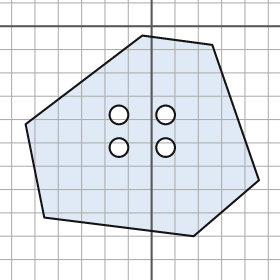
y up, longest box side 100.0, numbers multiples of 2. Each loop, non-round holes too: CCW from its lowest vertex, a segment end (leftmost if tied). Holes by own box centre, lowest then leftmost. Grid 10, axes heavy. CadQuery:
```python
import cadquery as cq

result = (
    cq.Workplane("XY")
    .moveTo(18.0, -90.0)
    .lineTo(46.0, -66.0)
    .lineTo(26.0, -8.0)
    .lineTo(-4.0, -4.0)
    .lineTo(-54.0, -42.0)
    .lineTo(-46.0, -82.0)
    .close()
    .moveTo(-14.0, -52.0)
    .circle(4.0)
    .moveTo(6.0, -52.0)
    .circle(4.0)
    .moveTo(-14.0, -38.0)
    .circle(4.0)
    .moveTo(6.0, -38.0)
    .circle(4.0)
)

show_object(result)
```